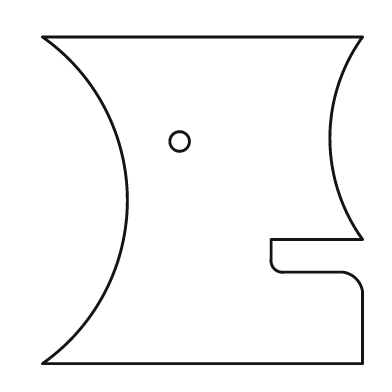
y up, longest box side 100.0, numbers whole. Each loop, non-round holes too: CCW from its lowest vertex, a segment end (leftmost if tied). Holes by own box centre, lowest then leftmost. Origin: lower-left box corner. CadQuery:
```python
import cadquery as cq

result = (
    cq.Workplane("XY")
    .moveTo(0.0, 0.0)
    .lineTo(98.0, 0.0)
    .lineTo(98.0, 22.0)
    .threePointArc((96.0, 26.0), (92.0, 28.0))
    .lineTo(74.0, 28.0)
    .threePointArc((71.0, 29.0), (70.0, 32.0))
    .lineTo(70.0, 38.0)
    .lineTo(98.0, 38.0)
    .threePointArc((88.0, 69.0), (98.0, 100.0))
    .lineTo(0.0, 100.0)
    .threePointArc((26.0, 50.0), (0.0, 0.0))
    .close()
    .moveTo(42.0, 68.0)
    .circle(3.0)
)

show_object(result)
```